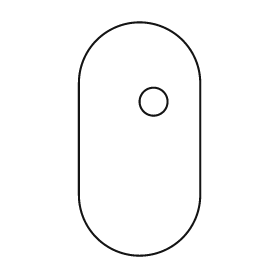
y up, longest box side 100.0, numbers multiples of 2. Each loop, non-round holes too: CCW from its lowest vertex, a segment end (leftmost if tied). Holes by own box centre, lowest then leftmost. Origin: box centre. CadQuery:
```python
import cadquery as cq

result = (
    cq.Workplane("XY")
    .moveTo(-26.0, -24.0)
    .threePointArc((0.0, -50.0), (26.0, -24.0))
    .lineTo(26.0, 24.0)
    .threePointArc((0.0, 50.0), (-26.0, 24.0))
    .close()
    .moveTo(6.0, 16.0)
    .circle(6.0)
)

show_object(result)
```